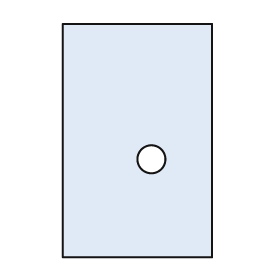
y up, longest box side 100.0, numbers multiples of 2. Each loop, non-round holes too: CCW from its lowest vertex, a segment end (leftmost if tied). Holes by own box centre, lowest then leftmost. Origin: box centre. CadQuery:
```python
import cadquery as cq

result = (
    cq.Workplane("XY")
    .moveTo(-32.0, -50.0)
    .lineTo(32.0, -50.0)
    .lineTo(32.0, 50.0)
    .lineTo(-32.0, 50.0)
    .close()
    .moveTo(6.0, -8.0)
    .circle(6.0)
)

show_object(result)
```